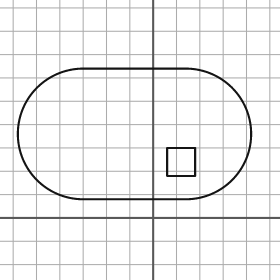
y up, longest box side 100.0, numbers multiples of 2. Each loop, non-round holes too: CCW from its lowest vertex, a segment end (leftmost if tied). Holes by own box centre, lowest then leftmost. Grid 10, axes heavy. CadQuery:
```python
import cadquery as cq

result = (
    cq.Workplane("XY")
    .moveTo(-30.0, 8.0)
    .lineTo(14.0, 8.0)
    .threePointArc((42.0, 36.0), (14.0, 64.0))
    .lineTo(-30.0, 64.0)
    .threePointArc((-58.0, 36.0), (-30.0, 8.0))
    .close()
    .moveTo(6.0, 18.0)
    .lineTo(18.0, 18.0)
    .lineTo(18.0, 30.0)
    .lineTo(6.0, 30.0)
    .close()
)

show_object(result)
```